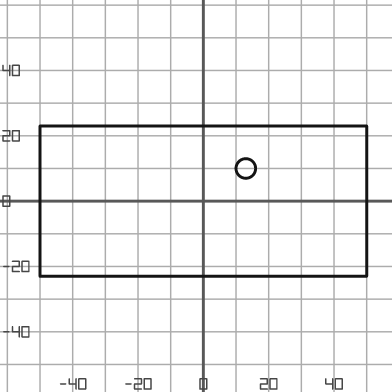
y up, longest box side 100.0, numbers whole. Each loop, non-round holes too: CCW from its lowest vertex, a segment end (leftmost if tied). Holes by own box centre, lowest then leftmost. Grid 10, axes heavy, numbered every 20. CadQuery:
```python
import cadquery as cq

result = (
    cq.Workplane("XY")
    .moveTo(-50.0, -23.0)
    .lineTo(50.0, -23.0)
    .lineTo(50.0, 23.0)
    .lineTo(-50.0, 23.0)
    .close()
    .moveTo(13.0, 10.0)
    .circle(3.0)
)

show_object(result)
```